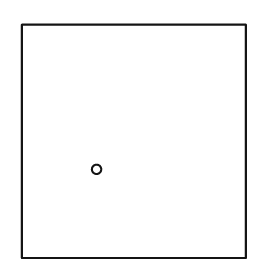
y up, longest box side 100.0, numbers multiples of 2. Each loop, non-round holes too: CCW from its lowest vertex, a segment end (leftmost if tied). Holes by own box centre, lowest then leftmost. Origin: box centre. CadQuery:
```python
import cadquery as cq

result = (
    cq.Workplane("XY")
    .moveTo(-48.0, -50.0)
    .lineTo(48.0, -50.0)
    .lineTo(48.0, 50.0)
    .lineTo(-48.0, 50.0)
    .close()
    .moveTo(-16.0, -12.0)
    .circle(2.0)
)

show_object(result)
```